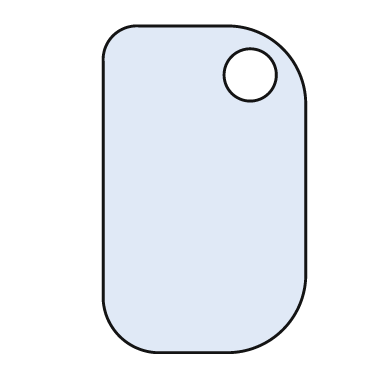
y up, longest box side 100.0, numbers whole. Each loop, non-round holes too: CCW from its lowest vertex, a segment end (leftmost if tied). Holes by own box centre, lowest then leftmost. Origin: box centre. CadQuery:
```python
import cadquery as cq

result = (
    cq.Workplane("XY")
    .moveTo(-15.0, -50.0)
    .lineTo(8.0, -50.0)
    .threePointArc((24.0, -43.0), (31.0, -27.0))
    .lineTo(31.0, 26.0)
    .threePointArc((24.0, 43.0), (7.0, 50.0))
    .lineTo(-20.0, 50.0)
    .threePointArc((-28.0, 47.0), (-31.0, 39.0))
    .lineTo(-31.0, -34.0)
    .threePointArc((-26.0, -45.0), (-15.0, -50.0))
    .close()
    .moveTo(14.0, 35.0)
    .circle(8.0)
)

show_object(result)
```